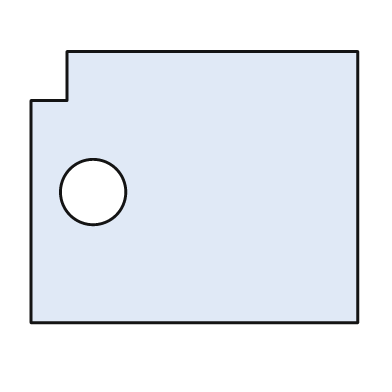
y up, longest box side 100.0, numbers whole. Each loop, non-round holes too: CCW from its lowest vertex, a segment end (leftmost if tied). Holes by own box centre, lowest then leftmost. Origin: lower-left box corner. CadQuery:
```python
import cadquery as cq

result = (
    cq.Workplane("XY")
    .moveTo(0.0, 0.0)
    .lineTo(100.0, 0.0)
    .lineTo(100.0, 83.0)
    .lineTo(11.0, 83.0)
    .lineTo(11.0, 68.0)
    .lineTo(0.0, 68.0)
    .close()
    .moveTo(19.0, 40.0)
    .circle(10.0)
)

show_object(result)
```